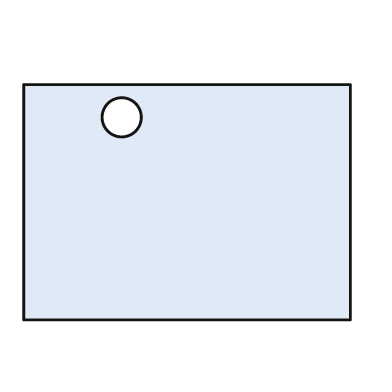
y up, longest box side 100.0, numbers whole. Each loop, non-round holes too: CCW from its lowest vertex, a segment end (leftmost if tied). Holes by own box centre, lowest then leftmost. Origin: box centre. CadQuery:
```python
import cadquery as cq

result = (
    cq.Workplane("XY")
    .moveTo(-50.0, -36.0)
    .lineTo(50.0, -36.0)
    .lineTo(50.0, 36.0)
    .lineTo(-50.0, 36.0)
    .close()
    .moveTo(-20.0, 26.0)
    .circle(6.0)
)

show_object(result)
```